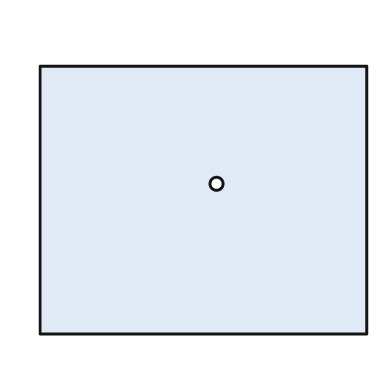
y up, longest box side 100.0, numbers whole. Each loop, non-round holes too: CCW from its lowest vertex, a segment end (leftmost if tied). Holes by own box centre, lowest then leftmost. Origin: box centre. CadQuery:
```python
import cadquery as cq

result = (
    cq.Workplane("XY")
    .moveTo(-50.0, -41.0)
    .lineTo(50.0, -41.0)
    .lineTo(50.0, 41.0)
    .lineTo(-50.0, 41.0)
    .close()
    .moveTo(4.0, 5.0)
    .circle(2.0)
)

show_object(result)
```